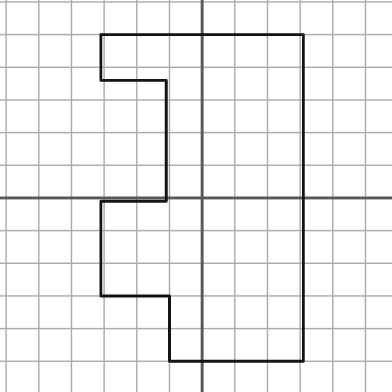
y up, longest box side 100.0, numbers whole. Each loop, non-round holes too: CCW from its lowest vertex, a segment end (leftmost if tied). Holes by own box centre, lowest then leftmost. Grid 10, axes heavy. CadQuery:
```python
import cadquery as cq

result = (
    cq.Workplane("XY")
    .moveTo(-10.0, -50.0)
    .lineTo(31.0, -50.0)
    .lineTo(31.0, 50.0)
    .lineTo(-31.0, 50.0)
    .lineTo(-31.0, 36.0)
    .lineTo(-11.0, 36.0)
    .lineTo(-11.0, -1.0)
    .lineTo(-31.0, -1.0)
    .lineTo(-31.0, -30.0)
    .lineTo(-10.0, -30.0)
    .close()
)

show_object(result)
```